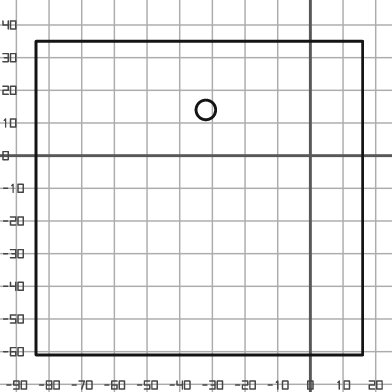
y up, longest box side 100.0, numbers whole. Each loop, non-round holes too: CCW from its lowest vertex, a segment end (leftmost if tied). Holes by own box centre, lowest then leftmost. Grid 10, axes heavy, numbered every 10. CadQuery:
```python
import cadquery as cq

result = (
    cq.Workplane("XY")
    .moveTo(-84.0, -61.0)
    .lineTo(16.0, -61.0)
    .lineTo(16.0, 35.0)
    .lineTo(-84.0, 35.0)
    .close()
    .moveTo(-32.0, 14.0)
    .circle(3.0)
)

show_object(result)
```